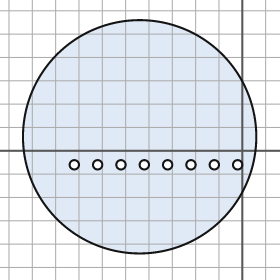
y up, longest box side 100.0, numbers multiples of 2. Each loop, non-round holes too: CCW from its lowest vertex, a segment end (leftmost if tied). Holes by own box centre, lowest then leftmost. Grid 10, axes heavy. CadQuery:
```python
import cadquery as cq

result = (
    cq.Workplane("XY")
    .moveTo(-44.0, 6.0)
    .circle(50.0)
    .moveTo(-72.0, -6.0)
    .circle(2.0)
    .moveTo(-62.0, -6.0)
    .circle(2.0)
    .moveTo(-52.0, -6.0)
    .circle(2.0)
    .moveTo(-42.0, -6.0)
    .circle(2.0)
    .moveTo(-32.0, -6.0)
    .circle(2.0)
    .moveTo(-22.0, -6.0)
    .circle(2.0)
    .moveTo(-12.0, -6.0)
    .circle(2.0)
    .moveTo(-2.0, -6.0)
    .circle(2.0)
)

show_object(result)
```